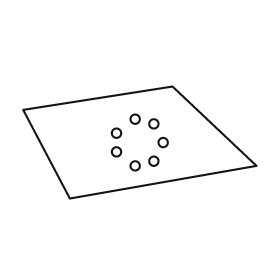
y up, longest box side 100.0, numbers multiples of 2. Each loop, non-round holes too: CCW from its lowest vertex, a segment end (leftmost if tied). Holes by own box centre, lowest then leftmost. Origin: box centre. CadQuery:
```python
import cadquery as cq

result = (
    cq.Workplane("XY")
    .moveTo(-30.0, -24.0)
    .lineTo(50.0, -10.0)
    .lineTo(14.0, 24.0)
    .lineTo(-50.0, 14.0)
    .close()
    .moveTo(-2.0, -10.0)
    .circle(2.0)
    .moveTo(6.0, -8.0)
    .circle(2.0)
    .moveTo(-10.0, -4.0)
    .circle(2.0)
    .moveTo(10.0, 0.0)
    .circle(2.0)
    .moveTo(-10.0, 4.0)
    .circle(2.0)
    .moveTo(6.0, 8.0)
    .circle(2.0)
    .moveTo(-2.0, 10.0)
    .circle(2.0)
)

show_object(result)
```